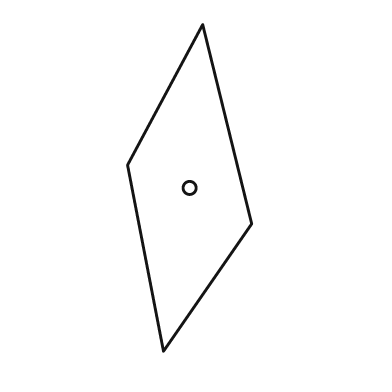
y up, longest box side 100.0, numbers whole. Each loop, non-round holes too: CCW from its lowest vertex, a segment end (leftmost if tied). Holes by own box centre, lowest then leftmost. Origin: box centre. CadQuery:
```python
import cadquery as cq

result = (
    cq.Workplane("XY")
    .moveTo(-8.0, -50.0)
    .lineTo(19.0, -11.0)
    .lineTo(4.0, 50.0)
    .lineTo(-19.0, 7.0)
    .close()
    .moveTo(0.0, 0.0)
    .circle(2.0)
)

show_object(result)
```